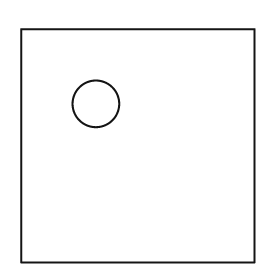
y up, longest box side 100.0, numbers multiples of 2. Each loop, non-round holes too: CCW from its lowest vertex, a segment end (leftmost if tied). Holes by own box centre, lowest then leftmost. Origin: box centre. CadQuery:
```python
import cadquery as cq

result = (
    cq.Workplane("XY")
    .moveTo(-50.0, -50.0)
    .lineTo(50.0, -50.0)
    .lineTo(50.0, 50.0)
    .lineTo(-50.0, 50.0)
    .close()
    .moveTo(-18.0, 18.0)
    .circle(10.0)
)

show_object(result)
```